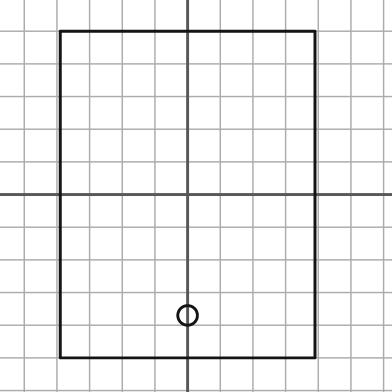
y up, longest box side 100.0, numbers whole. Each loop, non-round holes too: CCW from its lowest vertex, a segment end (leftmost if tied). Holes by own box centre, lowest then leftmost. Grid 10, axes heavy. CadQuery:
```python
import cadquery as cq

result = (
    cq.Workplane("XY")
    .moveTo(-39.0, -50.0)
    .lineTo(39.0, -50.0)
    .lineTo(39.0, 50.0)
    .lineTo(-39.0, 50.0)
    .close()
    .moveTo(0.0, -37.0)
    .circle(3.0)
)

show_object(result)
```